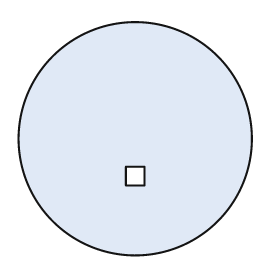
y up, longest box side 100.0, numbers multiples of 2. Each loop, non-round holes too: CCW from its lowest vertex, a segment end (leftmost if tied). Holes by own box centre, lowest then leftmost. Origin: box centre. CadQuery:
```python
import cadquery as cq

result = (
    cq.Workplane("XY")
    .moveTo(0.0, 0.0)
    .circle(50.0)
    .moveTo(-4.0, -20.0)
    .lineTo(4.0, -20.0)
    .lineTo(4.0, -12.0)
    .lineTo(-4.0, -12.0)
    .close()
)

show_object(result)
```